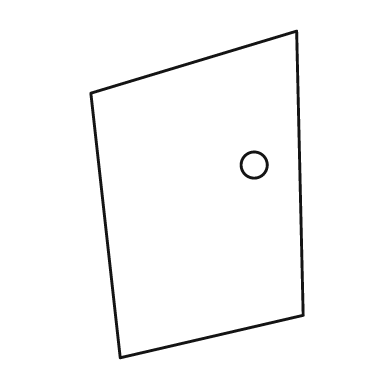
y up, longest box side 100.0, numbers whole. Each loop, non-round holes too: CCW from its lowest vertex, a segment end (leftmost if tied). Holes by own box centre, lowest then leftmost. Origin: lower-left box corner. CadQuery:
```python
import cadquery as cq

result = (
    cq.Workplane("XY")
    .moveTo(9.0, 0.0)
    .lineTo(65.0, 13.0)
    .lineTo(63.0, 100.0)
    .lineTo(0.0, 81.0)
    .close()
    .moveTo(50.0, 59.0)
    .circle(4.0)
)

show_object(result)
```